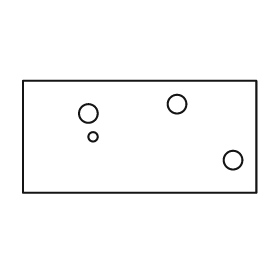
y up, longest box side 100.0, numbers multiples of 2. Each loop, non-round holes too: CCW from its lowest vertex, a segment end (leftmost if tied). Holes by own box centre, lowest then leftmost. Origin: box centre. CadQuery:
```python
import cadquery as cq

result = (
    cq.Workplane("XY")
    .moveTo(-50.0, -24.0)
    .lineTo(50.0, -24.0)
    .lineTo(50.0, 24.0)
    .lineTo(-50.0, 24.0)
    .close()
    .moveTo(40.0, -10.0)
    .circle(4.0)
    .moveTo(-20.0, 0.0)
    .circle(2.0)
    .moveTo(-22.0, 10.0)
    .circle(4.0)
    .moveTo(16.0, 14.0)
    .circle(4.0)
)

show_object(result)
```